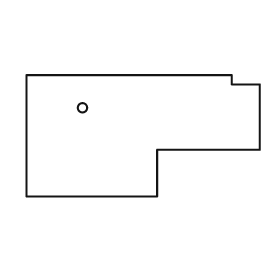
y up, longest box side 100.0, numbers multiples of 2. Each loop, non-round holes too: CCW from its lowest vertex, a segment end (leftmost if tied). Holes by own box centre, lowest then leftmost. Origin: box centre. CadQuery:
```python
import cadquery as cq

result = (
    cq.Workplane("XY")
    .moveTo(-50.0, -26.0)
    .lineTo(6.0, -26.0)
    .lineTo(6.0, -6.0)
    .lineTo(50.0, -6.0)
    .lineTo(50.0, 22.0)
    .lineTo(38.0, 22.0)
    .lineTo(38.0, 26.0)
    .lineTo(-50.0, 26.0)
    .close()
    .moveTo(-26.0, 12.0)
    .circle(2.0)
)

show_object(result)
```